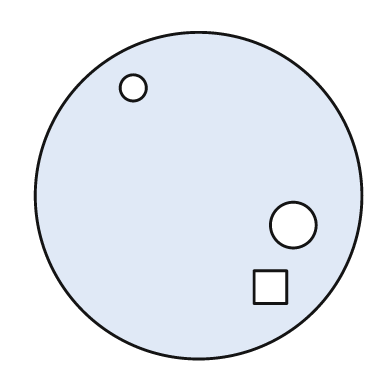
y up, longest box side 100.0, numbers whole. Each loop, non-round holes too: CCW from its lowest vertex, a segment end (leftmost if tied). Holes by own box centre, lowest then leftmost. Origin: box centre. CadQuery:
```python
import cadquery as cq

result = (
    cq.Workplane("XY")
    .moveTo(0.0, 0.0)
    .circle(50.0)
    .moveTo(17.0, -33.0)
    .lineTo(27.0, -33.0)
    .lineTo(27.0, -23.0)
    .lineTo(17.0, -23.0)
    .close()
    .moveTo(29.0, -9.0)
    .circle(7.0)
    .moveTo(-20.0, 33.0)
    .circle(4.0)
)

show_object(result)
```